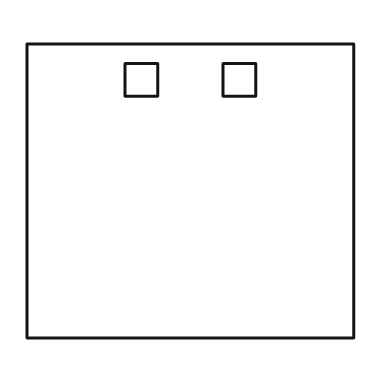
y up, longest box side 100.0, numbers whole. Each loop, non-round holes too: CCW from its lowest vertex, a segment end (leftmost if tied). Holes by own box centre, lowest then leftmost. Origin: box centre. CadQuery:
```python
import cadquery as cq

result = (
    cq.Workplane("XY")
    .moveTo(-50.0, -45.0)
    .lineTo(50.0, -45.0)
    .lineTo(50.0, 45.0)
    .lineTo(-50.0, 45.0)
    .close()
    .moveTo(-20.0, 29.0)
    .lineTo(-10.0, 29.0)
    .lineTo(-10.0, 39.0)
    .lineTo(-20.0, 39.0)
    .close()
    .moveTo(10.0, 29.0)
    .lineTo(20.0, 29.0)
    .lineTo(20.0, 39.0)
    .lineTo(10.0, 39.0)
    .close()
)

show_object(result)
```